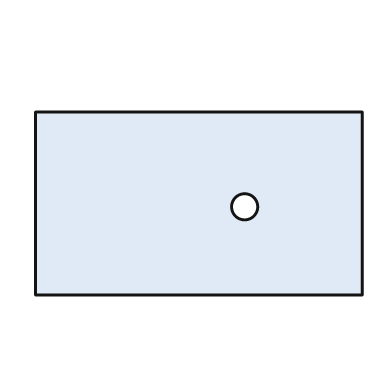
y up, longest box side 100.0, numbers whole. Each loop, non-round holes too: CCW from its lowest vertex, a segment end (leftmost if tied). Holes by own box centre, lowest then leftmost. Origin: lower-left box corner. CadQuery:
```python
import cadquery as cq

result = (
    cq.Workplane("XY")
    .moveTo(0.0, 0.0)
    .lineTo(100.0, 0.0)
    .lineTo(100.0, 56.0)
    .lineTo(0.0, 56.0)
    .close()
    .moveTo(64.0, 27.0)
    .circle(4.0)
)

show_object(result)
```